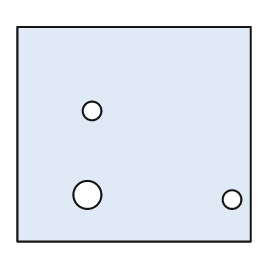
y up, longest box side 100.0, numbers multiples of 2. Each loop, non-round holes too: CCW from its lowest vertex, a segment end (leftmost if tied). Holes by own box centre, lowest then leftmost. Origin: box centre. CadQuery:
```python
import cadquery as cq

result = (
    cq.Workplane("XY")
    .moveTo(-50.0, -46.0)
    .lineTo(50.0, -46.0)
    .lineTo(50.0, 46.0)
    .lineTo(-50.0, 46.0)
    .close()
    .moveTo(42.0, -28.0)
    .circle(4.0)
    .moveTo(-20.0, -26.0)
    .circle(6.0)
    .moveTo(-18.0, 10.0)
    .circle(4.0)
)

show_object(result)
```